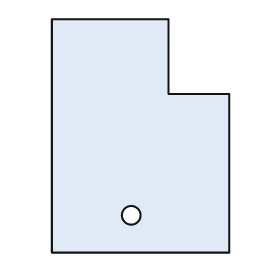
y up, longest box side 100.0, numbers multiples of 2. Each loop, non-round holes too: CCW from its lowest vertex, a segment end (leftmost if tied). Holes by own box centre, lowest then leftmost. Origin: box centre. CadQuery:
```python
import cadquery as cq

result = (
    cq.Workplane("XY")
    .moveTo(-38.0, -50.0)
    .lineTo(38.0, -50.0)
    .lineTo(38.0, 18.0)
    .lineTo(12.0, 18.0)
    .lineTo(12.0, 50.0)
    .lineTo(-38.0, 50.0)
    .close()
    .moveTo(-4.0, -34.0)
    .circle(4.0)
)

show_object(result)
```